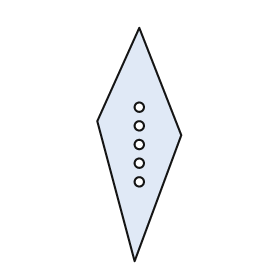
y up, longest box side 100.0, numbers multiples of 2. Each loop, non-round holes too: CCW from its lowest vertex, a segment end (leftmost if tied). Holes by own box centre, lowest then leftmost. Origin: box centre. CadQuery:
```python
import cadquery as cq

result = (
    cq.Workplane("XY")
    .moveTo(-2.0, -50.0)
    .lineTo(18.0, 4.0)
    .lineTo(0.0, 50.0)
    .lineTo(-18.0, 10.0)
    .close()
    .moveTo(0.0, -16.0)
    .circle(2.0)
    .moveTo(0.0, -8.0)
    .circle(2.0)
    .moveTo(0.0, 0.0)
    .circle(2.0)
    .moveTo(0.0, 8.0)
    .circle(2.0)
    .moveTo(0.0, 16.0)
    .circle(2.0)
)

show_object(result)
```